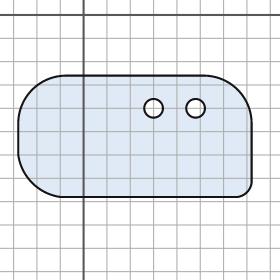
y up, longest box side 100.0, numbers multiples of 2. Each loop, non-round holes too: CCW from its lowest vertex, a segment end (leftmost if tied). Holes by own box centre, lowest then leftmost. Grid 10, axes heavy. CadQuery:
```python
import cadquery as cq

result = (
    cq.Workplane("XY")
    .moveTo(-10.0, -78.0)
    .lineTo(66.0, -78.0)
    .threePointArc((70.0, -76.0), (72.0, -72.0))
    .lineTo(72.0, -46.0)
    .threePointArc((66.0, -32.0), (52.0, -26.0))
    .lineTo(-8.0, -26.0)
    .threePointArc((-22.0, -32.0), (-28.0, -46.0))
    .lineTo(-28.0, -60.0)
    .threePointArc((-22.0, -72.0), (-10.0, -78.0))
    .close()
    .moveTo(30.0, -40.0)
    .circle(4.0)
    .moveTo(48.0, -40.0)
    .circle(4.0)
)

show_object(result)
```